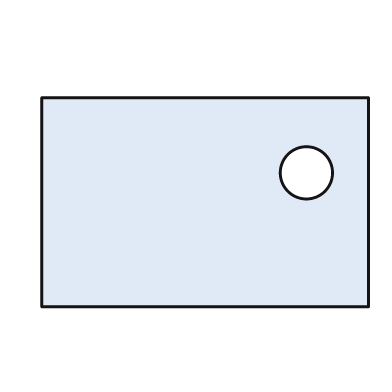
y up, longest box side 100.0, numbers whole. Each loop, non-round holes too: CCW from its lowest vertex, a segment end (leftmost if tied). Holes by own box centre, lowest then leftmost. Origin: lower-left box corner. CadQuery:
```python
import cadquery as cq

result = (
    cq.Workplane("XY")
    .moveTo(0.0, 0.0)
    .lineTo(100.0, 0.0)
    .lineTo(100.0, 64.0)
    .lineTo(0.0, 64.0)
    .close()
    .moveTo(81.0, 41.0)
    .circle(8.0)
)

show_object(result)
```